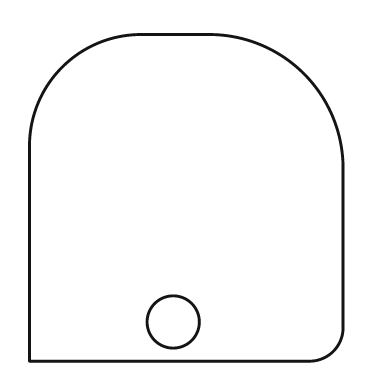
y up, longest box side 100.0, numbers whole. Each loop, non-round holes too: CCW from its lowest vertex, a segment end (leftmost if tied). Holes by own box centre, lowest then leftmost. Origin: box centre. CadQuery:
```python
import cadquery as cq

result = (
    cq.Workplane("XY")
    .moveTo(-48.0, -50.0)
    .lineTo(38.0, -50.0)
    .threePointArc((45.0, -47.0), (48.0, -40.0))
    .lineTo(48.0, 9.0)
    .threePointArc((36.0, 38.0), (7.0, 50.0))
    .lineTo(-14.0, 50.0)
    .threePointArc((-38.0, 40.0), (-48.0, 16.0))
    .close()
    .moveTo(-4.0, -38.0)
    .circle(8.0)
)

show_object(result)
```